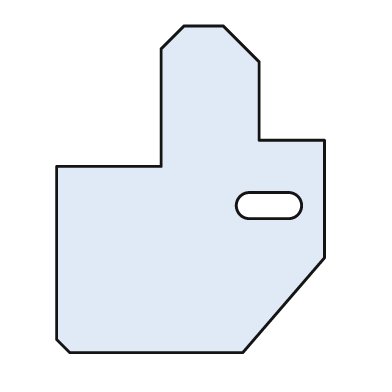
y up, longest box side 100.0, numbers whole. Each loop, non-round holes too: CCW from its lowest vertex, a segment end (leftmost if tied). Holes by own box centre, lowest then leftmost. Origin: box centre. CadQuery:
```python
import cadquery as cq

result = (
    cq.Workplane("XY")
    .moveTo(-37.0, -50.0)
    .lineTo(16.0, -50.0)
    .lineTo(41.0, -21.0)
    .lineTo(41.0, 15.0)
    .lineTo(21.0, 15.0)
    .lineTo(21.0, 39.0)
    .lineTo(10.0, 50.0)
    .lineTo(-2.0, 50.0)
    .lineTo(-9.0, 43.0)
    .lineTo(-9.0, 7.0)
    .lineTo(-41.0, 7.0)
    .lineTo(-41.0, -46.0)
    .close()
    .moveTo(18.0, -9.0)
    .lineTo(30.0, -9.0)
    .threePointArc((34.0, -5.0), (30.0, -1.0))
    .lineTo(18.0, -1.0)
    .threePointArc((14.0, -5.0), (18.0, -9.0))
    .close()
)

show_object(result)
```